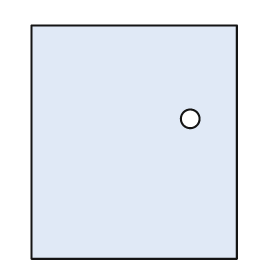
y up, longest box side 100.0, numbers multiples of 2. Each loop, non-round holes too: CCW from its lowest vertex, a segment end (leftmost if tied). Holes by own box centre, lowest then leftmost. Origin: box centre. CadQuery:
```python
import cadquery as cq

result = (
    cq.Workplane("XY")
    .moveTo(-44.0, -50.0)
    .lineTo(44.0, -50.0)
    .lineTo(44.0, 50.0)
    .lineTo(-44.0, 50.0)
    .close()
    .moveTo(24.0, 10.0)
    .circle(4.0)
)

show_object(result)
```